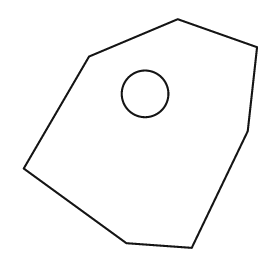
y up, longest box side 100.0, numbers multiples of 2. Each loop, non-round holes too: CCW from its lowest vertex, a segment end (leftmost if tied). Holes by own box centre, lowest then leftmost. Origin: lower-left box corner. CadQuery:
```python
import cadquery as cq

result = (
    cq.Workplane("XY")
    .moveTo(72.0, 0.0)
    .lineTo(96.0, 50.0)
    .lineTo(100.0, 86.0)
    .lineTo(66.0, 98.0)
    .lineTo(28.0, 82.0)
    .lineTo(0.0, 34.0)
    .lineTo(44.0, 2.0)
    .close()
    .moveTo(52.0, 66.0)
    .circle(10.0)
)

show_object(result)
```